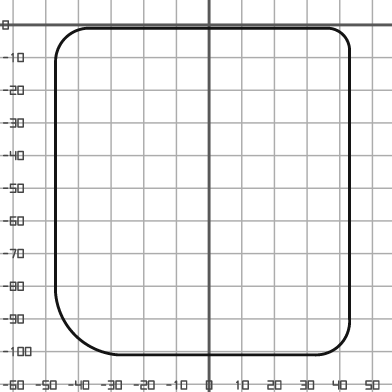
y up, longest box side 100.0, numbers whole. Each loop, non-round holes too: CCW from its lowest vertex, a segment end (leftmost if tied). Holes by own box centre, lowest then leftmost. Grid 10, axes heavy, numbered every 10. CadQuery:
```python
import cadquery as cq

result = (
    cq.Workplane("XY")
    .moveTo(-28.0, -101.0)
    .lineTo(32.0, -101.0)
    .threePointArc((40.0, -98.0), (43.0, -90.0))
    .lineTo(43.0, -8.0)
    .threePointArc((41.0, -3.0), (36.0, -1.0))
    .lineTo(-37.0, -1.0)
    .threePointArc((-44.0, -4.0), (-47.0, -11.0))
    .lineTo(-47.0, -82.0)
    .threePointArc((-41.0, -95.0), (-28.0, -101.0))
    .close()
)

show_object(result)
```